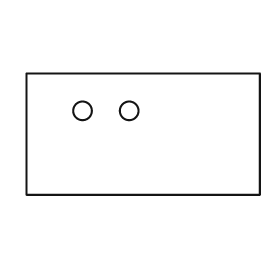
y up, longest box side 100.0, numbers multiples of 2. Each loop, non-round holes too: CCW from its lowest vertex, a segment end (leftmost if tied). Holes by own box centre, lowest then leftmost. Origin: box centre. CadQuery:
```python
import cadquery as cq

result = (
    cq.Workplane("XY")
    .moveTo(-50.0, -26.0)
    .lineTo(50.0, -26.0)
    .lineTo(50.0, 26.0)
    .lineTo(-50.0, 26.0)
    .close()
    .moveTo(-26.0, 10.0)
    .circle(4.0)
    .moveTo(-6.0, 10.0)
    .circle(4.0)
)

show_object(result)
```